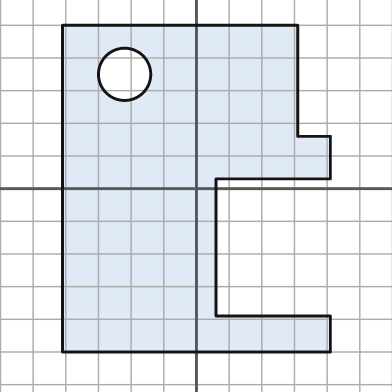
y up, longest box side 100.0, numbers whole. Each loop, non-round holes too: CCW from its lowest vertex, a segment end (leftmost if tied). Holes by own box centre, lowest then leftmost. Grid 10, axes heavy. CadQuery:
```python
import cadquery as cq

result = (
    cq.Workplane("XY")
    .moveTo(-41.0, -50.0)
    .lineTo(41.0, -50.0)
    .lineTo(41.0, -39.0)
    .lineTo(6.0, -39.0)
    .lineTo(6.0, 3.0)
    .lineTo(41.0, 3.0)
    .lineTo(41.0, 16.0)
    .lineTo(31.0, 16.0)
    .lineTo(31.0, 50.0)
    .lineTo(-41.0, 50.0)
    .close()
    .moveTo(-22.0, 35.0)
    .circle(8.0)
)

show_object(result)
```